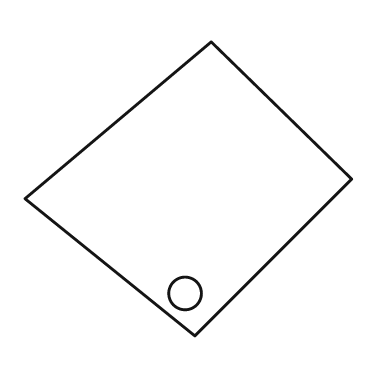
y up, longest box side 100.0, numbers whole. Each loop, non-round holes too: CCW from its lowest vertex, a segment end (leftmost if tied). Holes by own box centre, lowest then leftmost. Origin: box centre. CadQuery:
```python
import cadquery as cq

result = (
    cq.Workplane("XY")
    .moveTo(2.0, -45.0)
    .lineTo(50.0, 3.0)
    .lineTo(7.0, 45.0)
    .lineTo(-50.0, -3.0)
    .close()
    .moveTo(-1.0, -32.0)
    .circle(5.0)
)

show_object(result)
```